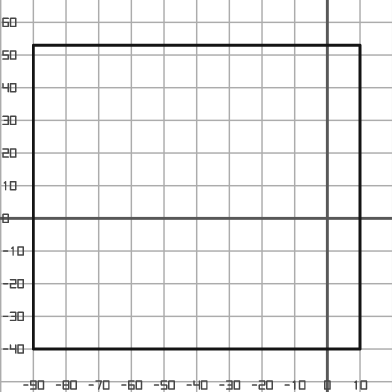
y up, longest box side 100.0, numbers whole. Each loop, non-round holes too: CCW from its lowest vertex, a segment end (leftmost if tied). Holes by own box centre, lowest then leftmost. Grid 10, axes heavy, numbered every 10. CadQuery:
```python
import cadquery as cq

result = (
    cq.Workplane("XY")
    .moveTo(-90.0, -40.0)
    .lineTo(10.0, -40.0)
    .lineTo(10.0, 53.0)
    .lineTo(-90.0, 53.0)
    .close()
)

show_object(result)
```